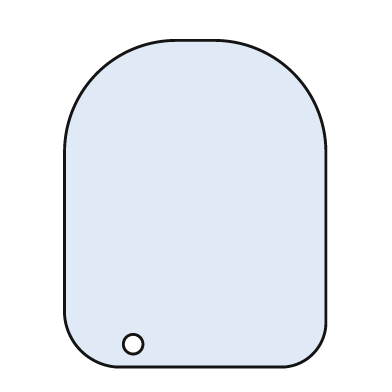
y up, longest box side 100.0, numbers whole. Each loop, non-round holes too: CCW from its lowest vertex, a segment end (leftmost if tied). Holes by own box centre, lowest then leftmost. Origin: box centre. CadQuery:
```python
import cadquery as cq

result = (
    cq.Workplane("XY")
    .moveTo(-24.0, -50.0)
    .lineTo(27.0, -50.0)
    .threePointArc((36.0, -46.0), (40.0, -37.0))
    .lineTo(40.0, 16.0)
    .threePointArc((30.0, 40.0), (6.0, 50.0))
    .lineTo(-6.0, 50.0)
    .threePointArc((-30.0, 40.0), (-40.0, 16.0))
    .lineTo(-40.0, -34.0)
    .threePointArc((-35.0, -45.0), (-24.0, -50.0))
    .close()
    .moveTo(-19.0, -43.0)
    .circle(3.0)
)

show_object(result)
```